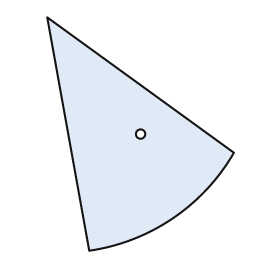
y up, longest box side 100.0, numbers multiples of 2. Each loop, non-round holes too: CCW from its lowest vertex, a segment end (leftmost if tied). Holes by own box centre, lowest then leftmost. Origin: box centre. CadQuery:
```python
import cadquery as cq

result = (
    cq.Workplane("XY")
    .moveTo(-22.0, -50.0)
    .threePointArc((14.0, -36.0), (40.0, -8.0))
    .lineTo(-40.0, 50.0)
    .close()
    .moveTo(0.0, 0.0)
    .circle(2.0)
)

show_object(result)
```